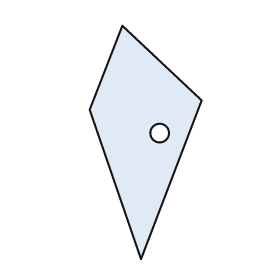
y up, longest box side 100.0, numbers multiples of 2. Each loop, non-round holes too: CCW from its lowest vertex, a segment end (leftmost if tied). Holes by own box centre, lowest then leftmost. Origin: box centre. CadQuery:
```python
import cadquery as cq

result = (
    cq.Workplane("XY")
    .moveTo(-2.0, -50.0)
    .lineTo(24.0, 18.0)
    .lineTo(-10.0, 50.0)
    .lineTo(-24.0, 14.0)
    .close()
    .moveTo(6.0, 4.0)
    .circle(4.0)
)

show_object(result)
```